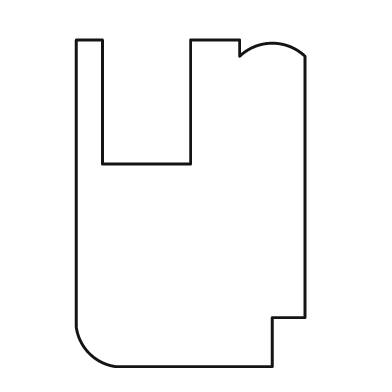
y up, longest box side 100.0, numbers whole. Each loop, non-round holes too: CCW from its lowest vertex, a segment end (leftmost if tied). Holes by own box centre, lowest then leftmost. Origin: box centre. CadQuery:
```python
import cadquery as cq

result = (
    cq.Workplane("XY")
    .moveTo(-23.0, -50.0)
    .lineTo(25.0, -50.0)
    .lineTo(25.0, -35.0)
    .lineTo(35.0, -35.0)
    .lineTo(35.0, 45.0)
    .threePointArc((25.0, 49.0), (15.0, 45.0))
    .lineTo(15.0, 50.0)
    .lineTo(0.0, 50.0)
    .lineTo(0.0, 12.0)
    .lineTo(-27.0, 12.0)
    .lineTo(-27.0, 50.0)
    .lineTo(-35.0, 50.0)
    .lineTo(-35.0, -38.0)
    .threePointArc((-31.0, -46.0), (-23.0, -50.0))
    .close()
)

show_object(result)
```